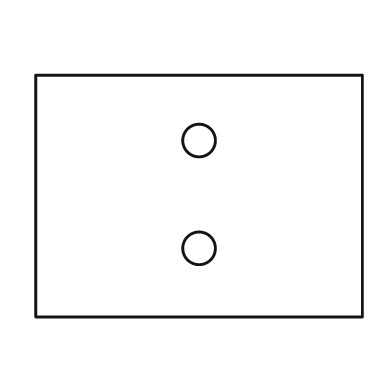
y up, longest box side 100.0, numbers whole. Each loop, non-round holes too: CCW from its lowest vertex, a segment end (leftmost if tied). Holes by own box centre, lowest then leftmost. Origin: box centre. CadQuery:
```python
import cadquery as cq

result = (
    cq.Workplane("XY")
    .moveTo(-50.0, -37.0)
    .lineTo(50.0, -37.0)
    .lineTo(50.0, 37.0)
    .lineTo(-50.0, 37.0)
    .close()
    .moveTo(0.0, -16.0)
    .circle(5.0)
    .moveTo(0.0, 17.0)
    .circle(5.0)
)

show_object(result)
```